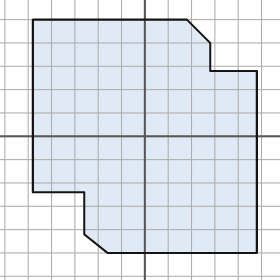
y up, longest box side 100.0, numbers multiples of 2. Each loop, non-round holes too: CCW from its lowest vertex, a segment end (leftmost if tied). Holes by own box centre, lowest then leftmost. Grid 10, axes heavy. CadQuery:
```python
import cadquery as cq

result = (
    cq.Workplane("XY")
    .moveTo(-16.0, -50.0)
    .lineTo(48.0, -50.0)
    .lineTo(48.0, 28.0)
    .lineTo(28.0, 28.0)
    .lineTo(28.0, 40.0)
    .lineTo(18.0, 50.0)
    .lineTo(-48.0, 50.0)
    .lineTo(-48.0, -24.0)
    .lineTo(-26.0, -24.0)
    .lineTo(-26.0, -42.0)
    .close()
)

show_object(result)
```